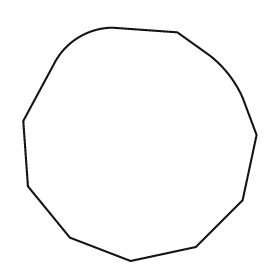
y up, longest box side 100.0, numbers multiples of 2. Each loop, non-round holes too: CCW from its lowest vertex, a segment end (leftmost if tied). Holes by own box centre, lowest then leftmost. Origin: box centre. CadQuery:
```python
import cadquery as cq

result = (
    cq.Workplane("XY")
    .moveTo(-4.0, -50.0)
    .lineTo(24.0, -44.0)
    .lineTo(44.0, -24.0)
    .lineTo(50.0, 4.0)
    .lineTo(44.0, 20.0)
    .threePointArc((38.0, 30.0), (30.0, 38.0))
    .lineTo(16.0, 48.0)
    .lineTo(-12.0, 50.0)
    .threePointArc((-26.0, 46.0), (-36.0, 36.0))
    .lineTo(-50.0, 10.0)
    .lineTo(-48.0, -18.0)
    .lineTo(-30.0, -40.0)
    .close()
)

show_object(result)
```